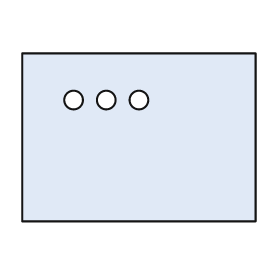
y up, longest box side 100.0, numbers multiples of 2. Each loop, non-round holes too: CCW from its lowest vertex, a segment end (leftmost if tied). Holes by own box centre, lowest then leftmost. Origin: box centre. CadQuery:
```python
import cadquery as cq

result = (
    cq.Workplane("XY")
    .moveTo(-50.0, -36.0)
    .lineTo(50.0, -36.0)
    .lineTo(50.0, 36.0)
    .lineTo(-50.0, 36.0)
    .close()
    .moveTo(-28.0, 16.0)
    .circle(4.0)
    .moveTo(-14.0, 16.0)
    .circle(4.0)
    .moveTo(0.0, 16.0)
    .circle(4.0)
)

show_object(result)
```